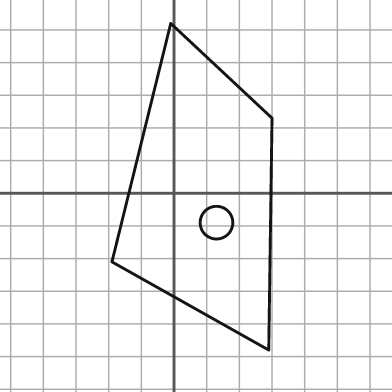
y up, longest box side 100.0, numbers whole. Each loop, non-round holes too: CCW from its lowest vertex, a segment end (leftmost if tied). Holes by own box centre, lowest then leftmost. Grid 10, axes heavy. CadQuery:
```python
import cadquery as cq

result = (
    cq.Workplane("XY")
    .moveTo(29.0, -48.0)
    .lineTo(30.0, 23.0)
    .lineTo(-1.0, 52.0)
    .lineTo(-19.0, -21.0)
    .close()
    .moveTo(13.0, -9.0)
    .circle(5.0)
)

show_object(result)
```